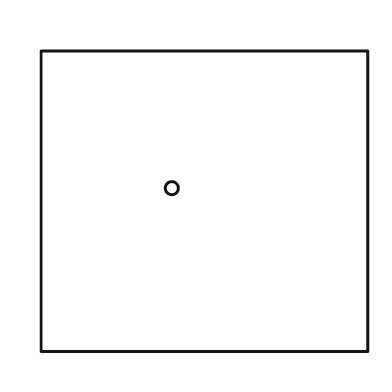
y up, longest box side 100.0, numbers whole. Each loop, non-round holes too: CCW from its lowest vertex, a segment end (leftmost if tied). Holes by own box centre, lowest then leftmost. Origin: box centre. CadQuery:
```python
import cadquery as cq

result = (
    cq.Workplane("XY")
    .moveTo(-50.0, -46.0)
    .lineTo(50.0, -46.0)
    .lineTo(50.0, 46.0)
    .lineTo(-50.0, 46.0)
    .close()
    .moveTo(-10.0, 4.0)
    .circle(2.0)
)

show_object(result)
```